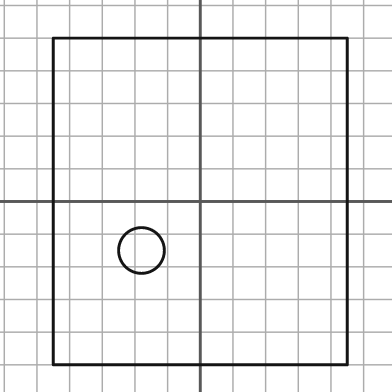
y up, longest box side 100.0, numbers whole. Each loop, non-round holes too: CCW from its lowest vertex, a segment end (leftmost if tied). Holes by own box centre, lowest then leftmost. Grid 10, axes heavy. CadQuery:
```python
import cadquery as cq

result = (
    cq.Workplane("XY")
    .moveTo(-45.0, -50.0)
    .lineTo(45.0, -50.0)
    .lineTo(45.0, 50.0)
    .lineTo(-45.0, 50.0)
    .close()
    .moveTo(-18.0, -15.0)
    .circle(7.0)
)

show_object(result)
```